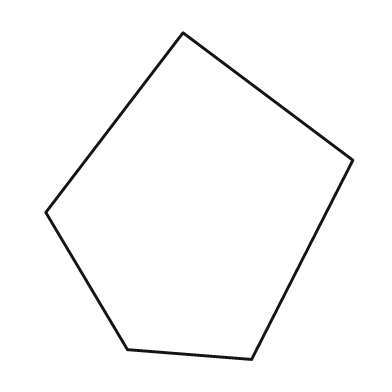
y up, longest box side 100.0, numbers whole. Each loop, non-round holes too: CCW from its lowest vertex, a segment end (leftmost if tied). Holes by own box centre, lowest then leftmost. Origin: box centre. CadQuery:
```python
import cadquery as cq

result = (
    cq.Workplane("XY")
    .moveTo(16.0, -50.0)
    .lineTo(47.0, 11.0)
    .lineTo(-5.0, 50.0)
    .lineTo(-47.0, -5.0)
    .lineTo(-22.0, -47.0)
    .close()
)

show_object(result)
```